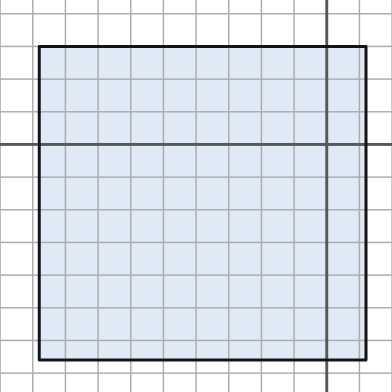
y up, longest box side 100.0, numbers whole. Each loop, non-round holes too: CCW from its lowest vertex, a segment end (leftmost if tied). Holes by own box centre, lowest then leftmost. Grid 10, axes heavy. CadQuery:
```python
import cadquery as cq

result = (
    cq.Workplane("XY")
    .moveTo(-88.0, -66.0)
    .lineTo(12.0, -66.0)
    .lineTo(12.0, 30.0)
    .lineTo(-88.0, 30.0)
    .close()
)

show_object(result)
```